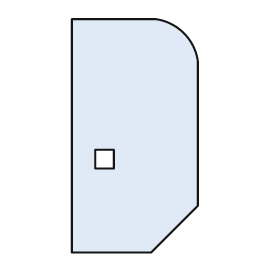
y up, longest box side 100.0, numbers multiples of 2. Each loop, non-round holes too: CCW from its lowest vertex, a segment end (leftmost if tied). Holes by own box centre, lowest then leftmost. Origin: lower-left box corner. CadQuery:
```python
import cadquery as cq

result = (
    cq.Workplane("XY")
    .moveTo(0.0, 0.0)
    .lineTo(34.0, 0.0)
    .lineTo(54.0, 20.0)
    .lineTo(54.0, 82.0)
    .threePointArc((48.0, 94.0), (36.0, 100.0))
    .lineTo(0.0, 100.0)
    .close()
    .moveTo(10.0, 36.0)
    .lineTo(18.0, 36.0)
    .lineTo(18.0, 44.0)
    .lineTo(10.0, 44.0)
    .close()
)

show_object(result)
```